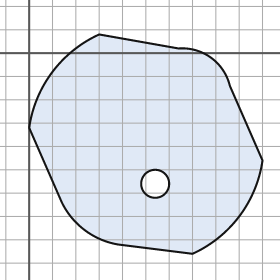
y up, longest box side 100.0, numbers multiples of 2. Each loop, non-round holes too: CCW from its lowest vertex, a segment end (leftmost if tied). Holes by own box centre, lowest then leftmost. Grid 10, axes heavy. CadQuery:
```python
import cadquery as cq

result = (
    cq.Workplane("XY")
    .moveTo(70.0, -86.0)
    .threePointArc((90.0, -70.0), (100.0, -46.0))
    .lineTo(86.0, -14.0)
    .threePointArc((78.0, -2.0), (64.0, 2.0))
    .lineTo(30.0, 8.0)
    .threePointArc((10.0, -8.0), (0.0, -32.0))
    .lineTo(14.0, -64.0)
    .threePointArc((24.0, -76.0), (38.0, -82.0))
    .close()
    .moveTo(54.0, -56.0)
    .circle(6.0)
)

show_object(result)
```